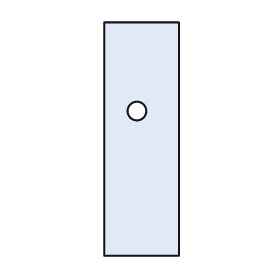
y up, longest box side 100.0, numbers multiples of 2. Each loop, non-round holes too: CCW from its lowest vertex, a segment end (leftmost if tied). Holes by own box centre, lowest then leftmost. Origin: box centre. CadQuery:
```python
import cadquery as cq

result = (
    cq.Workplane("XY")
    .moveTo(-16.0, -50.0)
    .lineTo(16.0, -50.0)
    .lineTo(16.0, 50.0)
    .lineTo(-16.0, 50.0)
    .close()
    .moveTo(-2.0, 12.0)
    .circle(4.0)
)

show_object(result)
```